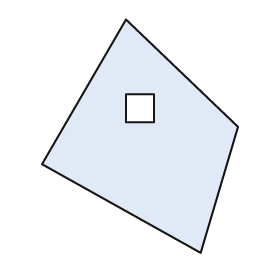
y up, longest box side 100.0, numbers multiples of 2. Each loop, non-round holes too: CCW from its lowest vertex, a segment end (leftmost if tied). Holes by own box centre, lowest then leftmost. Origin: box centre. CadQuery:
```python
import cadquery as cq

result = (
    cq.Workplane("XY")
    .moveTo(26.0, -50.0)
    .lineTo(42.0, 4.0)
    .lineTo(-6.0, 50.0)
    .lineTo(-42.0, -12.0)
    .close()
    .moveTo(-6.0, 6.0)
    .lineTo(6.0, 6.0)
    .lineTo(6.0, 18.0)
    .lineTo(-6.0, 18.0)
    .close()
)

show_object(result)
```